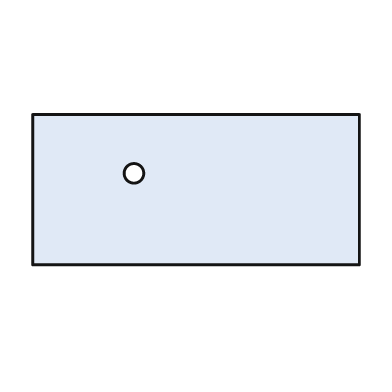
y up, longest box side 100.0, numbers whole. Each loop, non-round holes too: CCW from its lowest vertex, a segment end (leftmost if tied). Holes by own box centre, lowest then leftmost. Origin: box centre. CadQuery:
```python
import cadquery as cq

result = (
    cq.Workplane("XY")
    .moveTo(-50.0, -23.0)
    .lineTo(50.0, -23.0)
    .lineTo(50.0, 23.0)
    .lineTo(-50.0, 23.0)
    .close()
    .moveTo(-19.0, 5.0)
    .circle(3.0)
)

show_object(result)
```